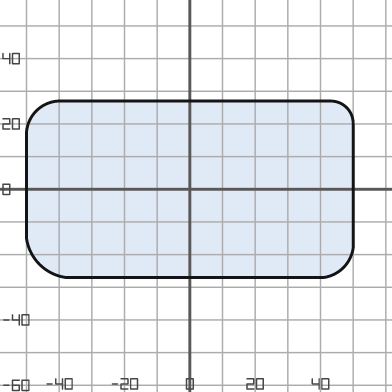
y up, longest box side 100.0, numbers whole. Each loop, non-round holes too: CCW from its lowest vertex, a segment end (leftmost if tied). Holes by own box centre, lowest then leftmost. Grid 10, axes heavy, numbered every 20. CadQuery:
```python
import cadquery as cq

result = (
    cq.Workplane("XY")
    .moveTo(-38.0, -27.0)
    .lineTo(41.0, -27.0)
    .threePointArc((47.0, -24.0), (50.0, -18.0))
    .lineTo(50.0, 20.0)
    .threePointArc((48.0, 25.0), (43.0, 27.0))
    .lineTo(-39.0, 27.0)
    .threePointArc((-47.0, 24.0), (-50.0, 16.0))
    .lineTo(-50.0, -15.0)
    .threePointArc((-46.0, -23.0), (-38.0, -27.0))
    .close()
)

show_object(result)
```